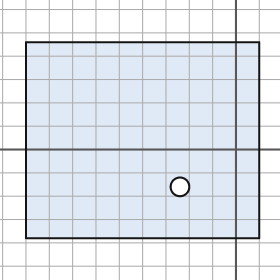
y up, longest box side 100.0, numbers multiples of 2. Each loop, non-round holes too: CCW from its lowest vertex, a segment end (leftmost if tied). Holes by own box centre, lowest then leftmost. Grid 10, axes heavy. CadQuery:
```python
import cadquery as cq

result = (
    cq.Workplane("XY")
    .moveTo(-90.0, -38.0)
    .lineTo(10.0, -38.0)
    .lineTo(10.0, 46.0)
    .lineTo(-90.0, 46.0)
    .close()
    .moveTo(-24.0, -16.0)
    .circle(4.0)
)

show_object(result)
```